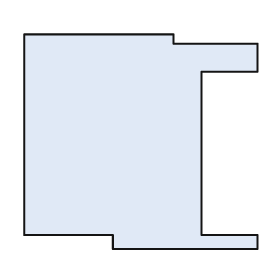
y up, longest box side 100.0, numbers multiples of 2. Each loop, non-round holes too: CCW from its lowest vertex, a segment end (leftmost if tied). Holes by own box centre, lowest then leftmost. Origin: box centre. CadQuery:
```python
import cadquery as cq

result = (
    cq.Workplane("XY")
    .moveTo(-12.0, -46.0)
    .lineTo(50.0, -46.0)
    .lineTo(50.0, -40.0)
    .lineTo(26.0, -40.0)
    .lineTo(26.0, 30.0)
    .lineTo(50.0, 30.0)
    .lineTo(50.0, 42.0)
    .lineTo(14.0, 42.0)
    .lineTo(14.0, 46.0)
    .lineTo(-50.0, 46.0)
    .lineTo(-50.0, -40.0)
    .lineTo(-12.0, -40.0)
    .close()
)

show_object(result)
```